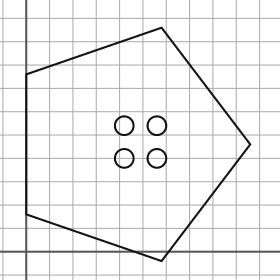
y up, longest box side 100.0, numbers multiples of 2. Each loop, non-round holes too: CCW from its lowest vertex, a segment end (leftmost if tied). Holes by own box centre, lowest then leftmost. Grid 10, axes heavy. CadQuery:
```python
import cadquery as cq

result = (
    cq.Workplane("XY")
    .moveTo(58.0, -4.0)
    .lineTo(96.0, 46.0)
    .lineTo(58.0, 96.0)
    .lineTo(0.0, 76.0)
    .lineTo(0.0, 16.0)
    .close()
    .moveTo(42.0, 40.0)
    .circle(4.0)
    .moveTo(56.0, 40.0)
    .circle(4.0)
    .moveTo(42.0, 54.0)
    .circle(4.0)
    .moveTo(56.0, 54.0)
    .circle(4.0)
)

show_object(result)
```